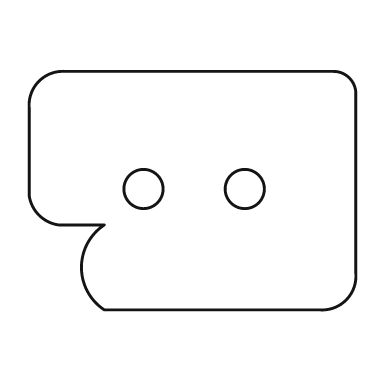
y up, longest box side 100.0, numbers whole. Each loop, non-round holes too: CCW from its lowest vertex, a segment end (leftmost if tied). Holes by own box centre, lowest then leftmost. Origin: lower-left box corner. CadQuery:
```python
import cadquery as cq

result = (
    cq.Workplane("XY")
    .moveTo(23.0, 0.0)
    .lineTo(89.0, 0.0)
    .threePointArc((97.0, 3.0), (100.0, 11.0))
    .lineTo(100.0, 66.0)
    .threePointArc((98.0, 71.0), (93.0, 73.0))
    .lineTo(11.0, 73.0)
    .threePointArc((3.0, 70.0), (0.0, 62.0))
    .lineTo(0.0, 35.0)
    .threePointArc((3.0, 29.0), (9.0, 26.0))
    .lineTo(23.0, 26.0)
    .threePointArc((16.0, 13.0), (23.0, 0.0))
    .close()
    .moveTo(35.0, 37.0)
    .circle(6.0)
    .moveTo(66.0, 37.0)
    .circle(6.0)
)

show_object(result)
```